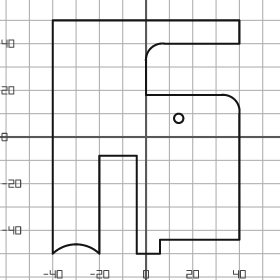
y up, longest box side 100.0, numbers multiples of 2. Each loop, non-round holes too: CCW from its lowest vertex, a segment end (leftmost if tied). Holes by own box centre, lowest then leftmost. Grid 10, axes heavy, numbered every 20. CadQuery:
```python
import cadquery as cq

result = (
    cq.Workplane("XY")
    .moveTo(-40.0, -50.0)
    .threePointArc((-30.0, -46.0), (-20.0, -50.0))
    .lineTo(-20.0, -8.0)
    .lineTo(-4.0, -8.0)
    .lineTo(-4.0, -50.0)
    .lineTo(6.0, -50.0)
    .lineTo(6.0, -44.0)
    .lineTo(40.0, -44.0)
    .lineTo(40.0, 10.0)
    .threePointArc((38.0, 16.0), (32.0, 18.0))
    .lineTo(0.0, 18.0)
    .lineTo(0.0, 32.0)
    .threePointArc((2.0, 38.0), (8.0, 40.0))
    .lineTo(40.0, 40.0)
    .lineTo(40.0, 50.0)
    .lineTo(-40.0, 50.0)
    .close()
    .moveTo(14.0, 8.0)
    .circle(2.0)
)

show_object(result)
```